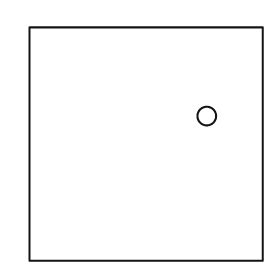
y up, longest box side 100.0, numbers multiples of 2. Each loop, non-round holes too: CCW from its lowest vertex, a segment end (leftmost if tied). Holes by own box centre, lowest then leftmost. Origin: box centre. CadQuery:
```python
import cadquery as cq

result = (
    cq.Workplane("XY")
    .moveTo(-50.0, -50.0)
    .lineTo(50.0, -50.0)
    .lineTo(50.0, 50.0)
    .lineTo(-50.0, 50.0)
    .close()
    .moveTo(26.0, 12.0)
    .circle(4.0)
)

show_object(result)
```